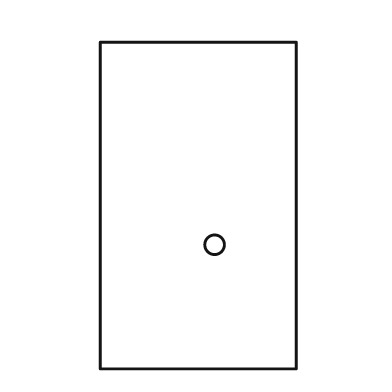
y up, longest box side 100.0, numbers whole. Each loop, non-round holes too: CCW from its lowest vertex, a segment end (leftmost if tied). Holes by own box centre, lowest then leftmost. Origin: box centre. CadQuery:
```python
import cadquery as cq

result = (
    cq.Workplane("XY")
    .moveTo(-30.0, -50.0)
    .lineTo(30.0, -50.0)
    .lineTo(30.0, 50.0)
    .lineTo(-30.0, 50.0)
    .close()
    .moveTo(5.0, -12.0)
    .circle(3.0)
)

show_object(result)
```